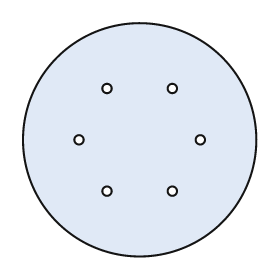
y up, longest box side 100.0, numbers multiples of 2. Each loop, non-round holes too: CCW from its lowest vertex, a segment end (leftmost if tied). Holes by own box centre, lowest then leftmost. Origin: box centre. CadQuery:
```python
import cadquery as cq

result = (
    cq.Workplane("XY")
    .moveTo(0.0, 0.0)
    .circle(50.0)
    .moveTo(-14.0, -22.0)
    .circle(2.0)
    .moveTo(14.0, -22.0)
    .circle(2.0)
    .moveTo(-26.0, 0.0)
    .circle(2.0)
    .moveTo(26.0, 0.0)
    .circle(2.0)
    .moveTo(-14.0, 22.0)
    .circle(2.0)
    .moveTo(14.0, 22.0)
    .circle(2.0)
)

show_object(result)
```